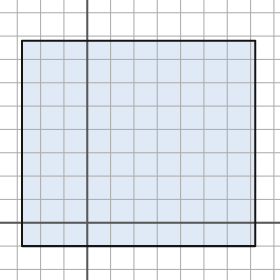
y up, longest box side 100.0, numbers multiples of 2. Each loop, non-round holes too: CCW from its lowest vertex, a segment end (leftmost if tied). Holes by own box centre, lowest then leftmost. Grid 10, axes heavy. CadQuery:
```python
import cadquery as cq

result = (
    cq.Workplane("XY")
    .moveTo(-28.0, -10.0)
    .lineTo(72.0, -10.0)
    .lineTo(72.0, 78.0)
    .lineTo(-28.0, 78.0)
    .close()
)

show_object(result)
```